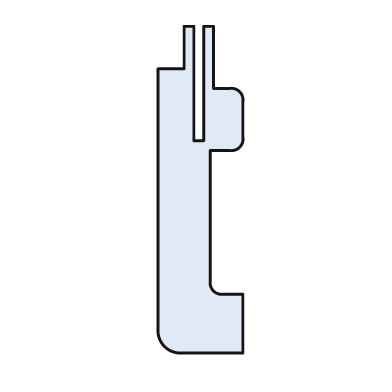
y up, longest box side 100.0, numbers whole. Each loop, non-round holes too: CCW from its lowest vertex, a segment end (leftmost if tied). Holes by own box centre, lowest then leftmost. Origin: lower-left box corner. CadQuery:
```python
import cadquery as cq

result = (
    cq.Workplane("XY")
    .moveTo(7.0, 0.0)
    .lineTo(26.0, 0.0)
    .lineTo(26.0, 18.0)
    .lineTo(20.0, 18.0)
    .threePointArc((17.0, 19.0), (16.0, 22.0))
    .lineTo(16.0, 62.0)
    .lineTo(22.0, 62.0)
    .threePointArc((25.0, 63.0), (26.0, 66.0))
    .lineTo(26.0, 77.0)
    .threePointArc((25.0, 80.0), (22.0, 81.0))
    .lineTo(17.0, 81.0)
    .lineTo(17.0, 100.0)
    .lineTo(14.0, 100.0)
    .lineTo(14.0, 65.0)
    .lineTo(11.0, 65.0)
    .lineTo(11.0, 100.0)
    .lineTo(8.0, 100.0)
    .lineTo(8.0, 87.0)
    .lineTo(0.0, 87.0)
    .lineTo(0.0, 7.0)
    .threePointArc((2.0, 2.0), (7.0, 0.0))
    .close()
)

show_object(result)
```